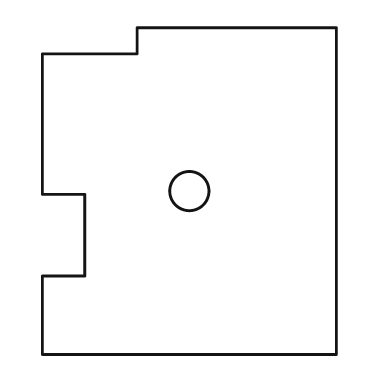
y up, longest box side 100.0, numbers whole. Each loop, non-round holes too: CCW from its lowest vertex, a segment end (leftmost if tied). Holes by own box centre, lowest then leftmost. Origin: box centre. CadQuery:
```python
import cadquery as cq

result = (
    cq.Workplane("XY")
    .moveTo(-45.0, -50.0)
    .lineTo(45.0, -50.0)
    .lineTo(45.0, 50.0)
    .lineTo(-16.0, 50.0)
    .lineTo(-16.0, 42.0)
    .lineTo(-45.0, 42.0)
    .lineTo(-45.0, -1.0)
    .lineTo(-32.0, -1.0)
    .lineTo(-32.0, -26.0)
    .lineTo(-45.0, -26.0)
    .close()
    .moveTo(0.0, 0.0)
    .circle(6.0)
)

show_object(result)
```